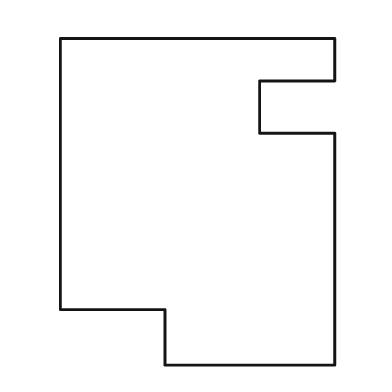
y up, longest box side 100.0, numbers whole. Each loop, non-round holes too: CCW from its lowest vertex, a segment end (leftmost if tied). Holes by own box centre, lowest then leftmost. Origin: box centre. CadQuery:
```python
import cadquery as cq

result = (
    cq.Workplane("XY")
    .moveTo(-10.0, -50.0)
    .lineTo(42.0, -50.0)
    .lineTo(42.0, 21.0)
    .lineTo(19.0, 21.0)
    .lineTo(19.0, 37.0)
    .lineTo(42.0, 37.0)
    .lineTo(42.0, 50.0)
    .lineTo(-42.0, 50.0)
    .lineTo(-42.0, -33.0)
    .lineTo(-10.0, -33.0)
    .close()
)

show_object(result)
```